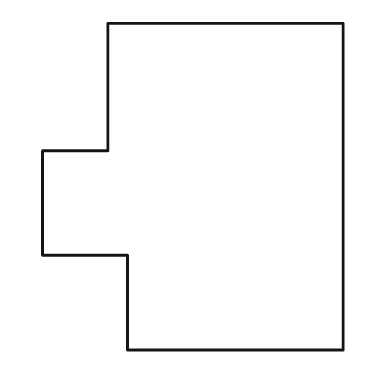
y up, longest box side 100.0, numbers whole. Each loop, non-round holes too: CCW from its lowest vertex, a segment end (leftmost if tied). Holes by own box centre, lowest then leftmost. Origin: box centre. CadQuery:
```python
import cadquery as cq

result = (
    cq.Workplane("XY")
    .moveTo(-20.0, -50.0)
    .lineTo(46.0, -50.0)
    .lineTo(46.0, 50.0)
    .lineTo(-26.0, 50.0)
    .lineTo(-26.0, 11.0)
    .lineTo(-46.0, 11.0)
    .lineTo(-46.0, -21.0)
    .lineTo(-20.0, -21.0)
    .close()
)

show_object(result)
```